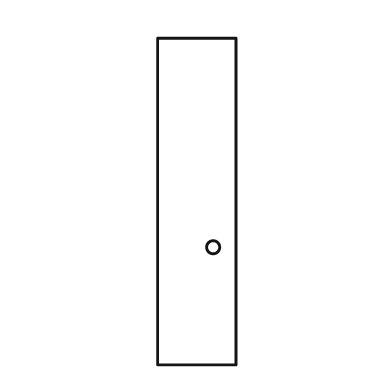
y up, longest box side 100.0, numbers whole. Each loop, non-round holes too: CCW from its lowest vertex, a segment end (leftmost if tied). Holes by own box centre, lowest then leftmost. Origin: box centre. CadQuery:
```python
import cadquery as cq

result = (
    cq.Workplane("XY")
    .moveTo(-12.0, -50.0)
    .lineTo(12.0, -50.0)
    .lineTo(12.0, 50.0)
    .lineTo(-12.0, 50.0)
    .close()
    .moveTo(5.0, -14.0)
    .circle(2.0)
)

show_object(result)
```